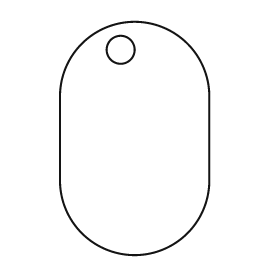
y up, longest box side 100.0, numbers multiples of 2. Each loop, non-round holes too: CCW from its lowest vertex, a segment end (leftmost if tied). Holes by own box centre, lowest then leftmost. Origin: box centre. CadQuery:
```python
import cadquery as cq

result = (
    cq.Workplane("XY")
    .moveTo(-32.0, -18.0)
    .threePointArc((0.0, -50.0), (32.0, -18.0))
    .lineTo(32.0, 18.0)
    .threePointArc((0.0, 50.0), (-32.0, 18.0))
    .close()
    .moveTo(-6.0, 38.0)
    .circle(6.0)
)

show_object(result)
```